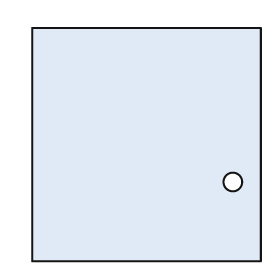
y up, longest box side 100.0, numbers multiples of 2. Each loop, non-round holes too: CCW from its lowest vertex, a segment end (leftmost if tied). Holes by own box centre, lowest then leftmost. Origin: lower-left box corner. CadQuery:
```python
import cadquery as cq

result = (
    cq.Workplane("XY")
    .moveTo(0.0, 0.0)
    .lineTo(98.0, 0.0)
    .lineTo(98.0, 100.0)
    .lineTo(0.0, 100.0)
    .close()
    .moveTo(86.0, 34.0)
    .circle(4.0)
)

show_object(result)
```